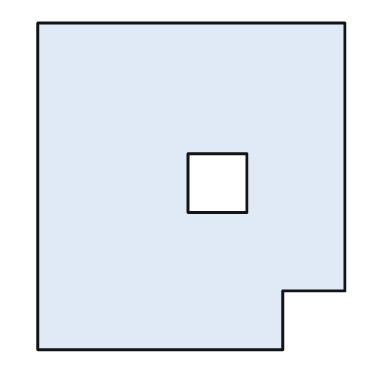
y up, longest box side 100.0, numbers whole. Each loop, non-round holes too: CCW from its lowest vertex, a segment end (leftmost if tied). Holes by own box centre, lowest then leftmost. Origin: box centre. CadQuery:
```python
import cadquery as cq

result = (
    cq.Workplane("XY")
    .moveTo(-47.0, -50.0)
    .lineTo(28.0, -50.0)
    .lineTo(28.0, -32.0)
    .lineTo(47.0, -32.0)
    .lineTo(47.0, 50.0)
    .lineTo(-47.0, 50.0)
    .close()
    .moveTo(-1.0, -8.0)
    .lineTo(17.0, -8.0)
    .lineTo(17.0, 10.0)
    .lineTo(-1.0, 10.0)
    .close()
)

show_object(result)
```